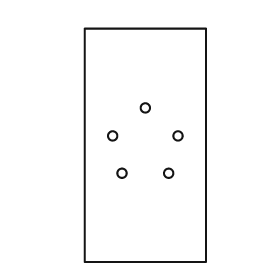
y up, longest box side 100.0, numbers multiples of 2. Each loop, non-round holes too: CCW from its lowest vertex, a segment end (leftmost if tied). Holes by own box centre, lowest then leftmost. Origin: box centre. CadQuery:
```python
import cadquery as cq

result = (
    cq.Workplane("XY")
    .moveTo(-26.0, -50.0)
    .lineTo(26.0, -50.0)
    .lineTo(26.0, 50.0)
    .lineTo(-26.0, 50.0)
    .close()
    .moveTo(-10.0, -12.0)
    .circle(2.0)
    .moveTo(10.0, -12.0)
    .circle(2.0)
    .moveTo(-14.0, 4.0)
    .circle(2.0)
    .moveTo(14.0, 4.0)
    .circle(2.0)
    .moveTo(0.0, 16.0)
    .circle(2.0)
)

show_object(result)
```